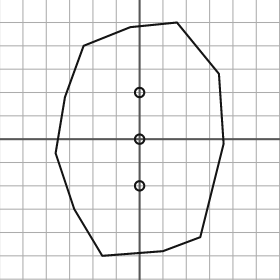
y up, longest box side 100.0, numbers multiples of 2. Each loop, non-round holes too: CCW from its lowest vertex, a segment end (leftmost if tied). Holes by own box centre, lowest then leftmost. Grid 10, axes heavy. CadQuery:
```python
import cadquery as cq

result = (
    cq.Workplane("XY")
    .moveTo(-16.0, -50.0)
    .lineTo(10.0, -48.0)
    .lineTo(26.0, -42.0)
    .lineTo(36.0, -2.0)
    .lineTo(34.0, 28.0)
    .lineTo(16.0, 50.0)
    .lineTo(-4.0, 48.0)
    .lineTo(-24.0, 40.0)
    .lineTo(-32.0, 18.0)
    .lineTo(-36.0, -6.0)
    .lineTo(-28.0, -30.0)
    .close()
    .moveTo(0.0, -20.0)
    .circle(2.0)
    .moveTo(0.0, 0.0)
    .circle(2.0)
    .moveTo(0.0, 20.0)
    .circle(2.0)
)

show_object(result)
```